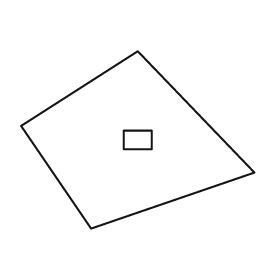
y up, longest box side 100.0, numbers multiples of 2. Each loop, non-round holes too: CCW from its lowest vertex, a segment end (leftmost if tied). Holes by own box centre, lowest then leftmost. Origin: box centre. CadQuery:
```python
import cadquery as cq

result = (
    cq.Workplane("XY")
    .moveTo(-20.0, -38.0)
    .lineTo(50.0, -14.0)
    .lineTo(0.0, 38.0)
    .lineTo(-50.0, 6.0)
    .close()
    .moveTo(-6.0, -4.0)
    .lineTo(6.0, -4.0)
    .lineTo(6.0, 4.0)
    .lineTo(-6.0, 4.0)
    .close()
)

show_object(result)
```